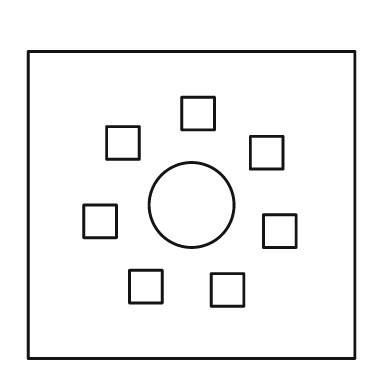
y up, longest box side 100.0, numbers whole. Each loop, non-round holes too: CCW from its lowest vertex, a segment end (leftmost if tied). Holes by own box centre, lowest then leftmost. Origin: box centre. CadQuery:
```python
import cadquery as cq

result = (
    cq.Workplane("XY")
    .moveTo(-50.0, -47.0)
    .lineTo(50.0, -47.0)
    .lineTo(50.0, 47.0)
    .lineTo(-50.0, 47.0)
    .close()
    .moveTo(6.0, -31.0)
    .lineTo(16.0, -31.0)
    .lineTo(16.0, -21.0)
    .lineTo(6.0, -21.0)
    .close()
    .moveTo(-19.0, -30.0)
    .lineTo(-9.0, -30.0)
    .lineTo(-9.0, -20.0)
    .lineTo(-19.0, -20.0)
    .close()
    .moveTo(22.0, -13.0)
    .lineTo(32.0, -13.0)
    .lineTo(32.0, -3.0)
    .lineTo(22.0, -3.0)
    .close()
    .moveTo(-33.0, -10.0)
    .lineTo(-23.0, -10.0)
    .lineTo(-23.0, 0.0)
    .lineTo(-33.0, 0.0)
    .close()
    .moveTo(0.0, 0.0)
    .circle(13.0)
    .moveTo(18.0, 11.0)
    .lineTo(28.0, 11.0)
    .lineTo(28.0, 21.0)
    .lineTo(18.0, 21.0)
    .close()
    .moveTo(-26.0, 14.0)
    .lineTo(-16.0, 14.0)
    .lineTo(-16.0, 24.0)
    .lineTo(-26.0, 24.0)
    .close()
    .moveTo(-3.0, 23.0)
    .lineTo(7.0, 23.0)
    .lineTo(7.0, 33.0)
    .lineTo(-3.0, 33.0)
    .close()
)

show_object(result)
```